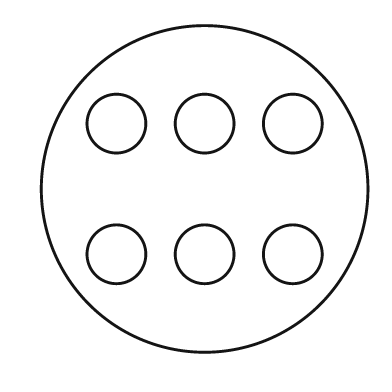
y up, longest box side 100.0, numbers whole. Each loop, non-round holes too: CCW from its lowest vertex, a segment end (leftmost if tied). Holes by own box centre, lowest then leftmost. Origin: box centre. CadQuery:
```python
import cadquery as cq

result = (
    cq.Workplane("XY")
    .moveTo(0.0, 0.0)
    .circle(50.0)
    .moveTo(-27.0, -20.0)
    .circle(9.0)
    .moveTo(0.0, -20.0)
    .circle(9.0)
    .moveTo(27.0, -20.0)
    .circle(9.0)
    .moveTo(-27.0, 20.0)
    .circle(9.0)
    .moveTo(0.0, 20.0)
    .circle(9.0)
    .moveTo(27.0, 20.0)
    .circle(9.0)
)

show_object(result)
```